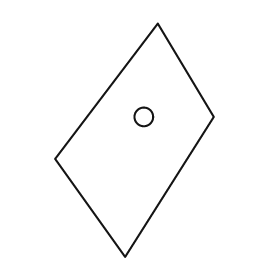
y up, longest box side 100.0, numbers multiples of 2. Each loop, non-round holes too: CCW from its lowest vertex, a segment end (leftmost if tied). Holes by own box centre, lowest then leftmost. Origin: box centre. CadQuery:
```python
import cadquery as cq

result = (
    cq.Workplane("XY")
    .moveTo(-4.0, -50.0)
    .lineTo(34.0, 10.0)
    .lineTo(10.0, 50.0)
    .lineTo(-34.0, -8.0)
    .close()
    .moveTo(4.0, 10.0)
    .circle(4.0)
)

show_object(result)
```